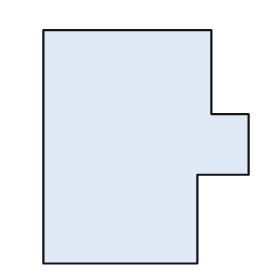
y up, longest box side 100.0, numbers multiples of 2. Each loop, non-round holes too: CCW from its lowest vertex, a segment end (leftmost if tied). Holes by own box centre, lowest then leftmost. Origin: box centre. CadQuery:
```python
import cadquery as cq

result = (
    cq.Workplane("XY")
    .moveTo(-44.0, -50.0)
    .lineTo(22.0, -50.0)
    .lineTo(22.0, -12.0)
    .lineTo(44.0, -12.0)
    .lineTo(44.0, 14.0)
    .lineTo(28.0, 14.0)
    .lineTo(28.0, 50.0)
    .lineTo(-44.0, 50.0)
    .close()
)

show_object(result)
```